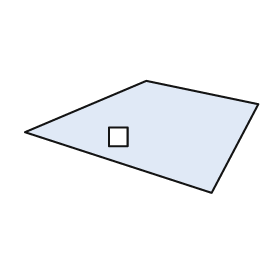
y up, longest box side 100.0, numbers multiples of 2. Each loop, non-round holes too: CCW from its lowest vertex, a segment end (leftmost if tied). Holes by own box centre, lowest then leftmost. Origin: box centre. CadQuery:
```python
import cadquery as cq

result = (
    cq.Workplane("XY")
    .moveTo(30.0, -24.0)
    .lineTo(50.0, 14.0)
    .lineTo(2.0, 24.0)
    .lineTo(-50.0, 2.0)
    .close()
    .moveTo(-14.0, -4.0)
    .lineTo(-6.0, -4.0)
    .lineTo(-6.0, 4.0)
    .lineTo(-14.0, 4.0)
    .close()
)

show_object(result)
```